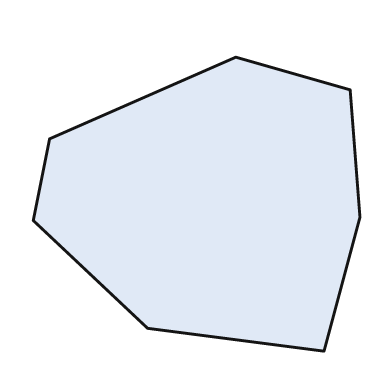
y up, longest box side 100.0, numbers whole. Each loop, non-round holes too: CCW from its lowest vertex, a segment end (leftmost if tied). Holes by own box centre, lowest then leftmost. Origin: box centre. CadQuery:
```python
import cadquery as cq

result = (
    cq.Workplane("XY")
    .moveTo(39.0, -45.0)
    .lineTo(50.0, -4.0)
    .lineTo(47.0, 35.0)
    .lineTo(12.0, 45.0)
    .lineTo(-45.0, 20.0)
    .lineTo(-50.0, -5.0)
    .lineTo(-15.0, -38.0)
    .close()
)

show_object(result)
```